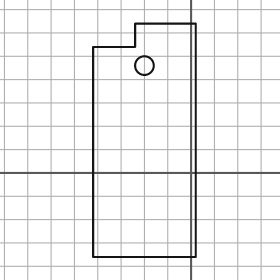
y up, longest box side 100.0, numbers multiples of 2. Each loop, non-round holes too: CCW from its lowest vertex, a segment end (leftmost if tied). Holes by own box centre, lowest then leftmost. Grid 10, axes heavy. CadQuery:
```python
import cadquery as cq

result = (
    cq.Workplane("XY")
    .moveTo(-42.0, -36.0)
    .lineTo(2.0, -36.0)
    .lineTo(2.0, 64.0)
    .lineTo(-24.0, 64.0)
    .lineTo(-24.0, 54.0)
    .lineTo(-42.0, 54.0)
    .close()
    .moveTo(-20.0, 46.0)
    .circle(4.0)
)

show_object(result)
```